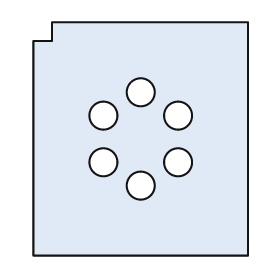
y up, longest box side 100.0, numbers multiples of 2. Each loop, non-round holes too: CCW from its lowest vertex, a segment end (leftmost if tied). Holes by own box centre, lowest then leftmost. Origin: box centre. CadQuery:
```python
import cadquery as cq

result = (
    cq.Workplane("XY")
    .moveTo(-46.0, -50.0)
    .lineTo(46.0, -50.0)
    .lineTo(46.0, 50.0)
    .lineTo(-38.0, 50.0)
    .lineTo(-38.0, 42.0)
    .lineTo(-46.0, 42.0)
    .close()
    .moveTo(0.0, -20.0)
    .circle(6.0)
    .moveTo(-16.0, -10.0)
    .circle(6.0)
    .moveTo(16.0, -10.0)
    .circle(6.0)
    .moveTo(-16.0, 10.0)
    .circle(6.0)
    .moveTo(16.0, 10.0)
    .circle(6.0)
    .moveTo(0.0, 20.0)
    .circle(6.0)
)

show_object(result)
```